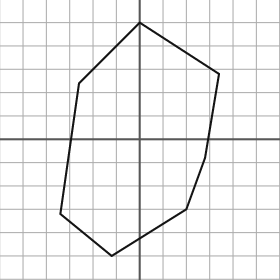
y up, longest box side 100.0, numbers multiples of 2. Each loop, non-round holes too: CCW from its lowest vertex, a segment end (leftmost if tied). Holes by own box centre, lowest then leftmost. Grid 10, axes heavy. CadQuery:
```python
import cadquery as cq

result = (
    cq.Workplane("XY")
    .moveTo(-12.0, -50.0)
    .lineTo(20.0, -30.0)
    .lineTo(28.0, -8.0)
    .lineTo(34.0, 28.0)
    .lineTo(0.0, 50.0)
    .lineTo(-26.0, 24.0)
    .lineTo(-34.0, -32.0)
    .close()
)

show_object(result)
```